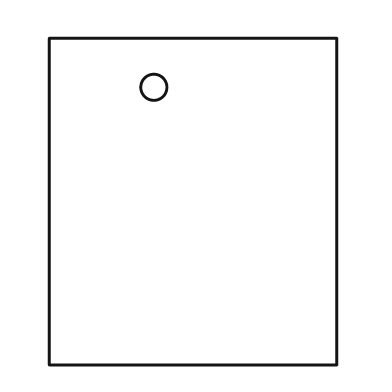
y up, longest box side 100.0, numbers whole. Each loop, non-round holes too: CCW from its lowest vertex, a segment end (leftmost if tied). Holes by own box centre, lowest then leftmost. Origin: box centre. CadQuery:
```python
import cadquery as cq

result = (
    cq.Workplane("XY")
    .moveTo(-44.0, -50.0)
    .lineTo(44.0, -50.0)
    .lineTo(44.0, 50.0)
    .lineTo(-44.0, 50.0)
    .close()
    .moveTo(-12.0, 35.0)
    .circle(4.0)
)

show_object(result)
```